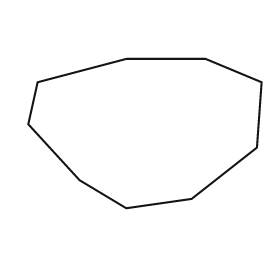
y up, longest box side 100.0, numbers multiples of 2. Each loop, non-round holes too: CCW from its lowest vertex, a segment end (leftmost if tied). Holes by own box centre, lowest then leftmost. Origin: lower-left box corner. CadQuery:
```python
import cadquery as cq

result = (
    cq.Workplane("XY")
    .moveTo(42.0, 0.0)
    .lineTo(70.0, 4.0)
    .lineTo(98.0, 26.0)
    .lineTo(100.0, 54.0)
    .lineTo(76.0, 64.0)
    .lineTo(42.0, 64.0)
    .lineTo(4.0, 54.0)
    .lineTo(0.0, 36.0)
    .lineTo(22.0, 12.0)
    .close()
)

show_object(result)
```